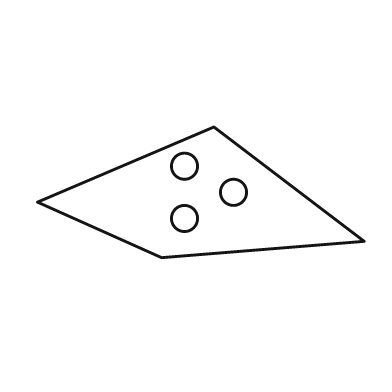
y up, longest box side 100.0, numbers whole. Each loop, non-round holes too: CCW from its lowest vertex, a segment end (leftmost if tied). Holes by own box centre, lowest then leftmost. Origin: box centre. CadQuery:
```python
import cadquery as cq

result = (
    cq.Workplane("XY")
    .moveTo(-12.0, -20.0)
    .lineTo(50.0, -15.0)
    .lineTo(4.0, 20.0)
    .lineTo(-50.0, -3.0)
    .close()
    .moveTo(-5.0, -8.0)
    .circle(4.0)
    .moveTo(10.0, 0.0)
    .circle(4.0)
    .moveTo(-5.0, 8.0)
    .circle(4.0)
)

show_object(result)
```